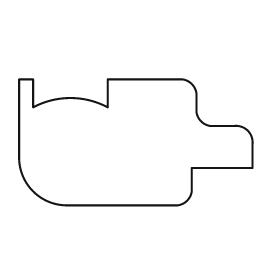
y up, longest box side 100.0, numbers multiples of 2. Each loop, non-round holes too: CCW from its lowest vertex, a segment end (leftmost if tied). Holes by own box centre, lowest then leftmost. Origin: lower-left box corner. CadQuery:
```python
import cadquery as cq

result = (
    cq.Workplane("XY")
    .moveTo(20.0, 0.0)
    .lineTo(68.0, 0.0)
    .threePointArc((72.0, 2.0), (74.0, 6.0))
    .lineTo(74.0, 16.0)
    .lineTo(100.0, 16.0)
    .lineTo(100.0, 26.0)
    .threePointArc((98.0, 32.0), (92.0, 34.0))
    .lineTo(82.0, 34.0)
    .threePointArc((78.0, 36.0), (76.0, 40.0))
    .lineTo(76.0, 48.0)
    .threePointArc((74.0, 52.0), (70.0, 54.0))
    .lineTo(38.0, 54.0)
    .lineTo(38.0, 42.0)
    .threePointArc((22.0, 46.0), (6.0, 42.0))
    .lineTo(6.0, 54.0)
    .lineTo(0.0, 54.0)
    .lineTo(0.0, 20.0)
    .threePointArc((6.0, 6.0), (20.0, 0.0))
    .close()
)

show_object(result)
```